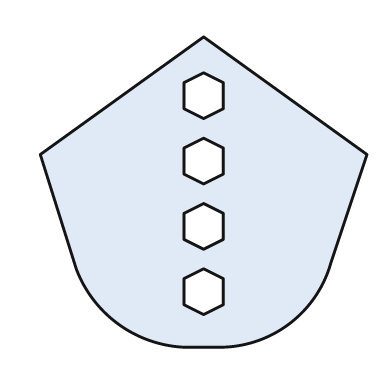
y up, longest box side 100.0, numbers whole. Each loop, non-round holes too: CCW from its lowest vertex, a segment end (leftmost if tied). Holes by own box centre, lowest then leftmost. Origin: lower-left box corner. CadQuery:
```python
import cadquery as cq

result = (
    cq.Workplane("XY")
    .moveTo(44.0, 0.0)
    .lineTo(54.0, 0.0)
    .threePointArc((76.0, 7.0), (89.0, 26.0))
    .lineTo(100.0, 59.0)
    .lineTo(50.0, 95.0)
    .lineTo(0.0, 59.0)
    .lineTo(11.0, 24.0)
    .threePointArc((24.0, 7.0), (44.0, 0.0))
    .close()
    .moveTo(50.0, 10.0)
    .lineTo(56.0, 13.0)
    .lineTo(56.0, 21.0)
    .lineTo(50.0, 24.0)
    .lineTo(44.0, 21.0)
    .lineTo(44.0, 13.0)
    .close()
    .moveTo(50.0, 30.0)
    .lineTo(56.0, 33.0)
    .lineTo(56.0, 41.0)
    .lineTo(50.0, 44.0)
    .lineTo(44.0, 41.0)
    .lineTo(44.0, 33.0)
    .close()
    .moveTo(50.0, 50.0)
    .lineTo(56.0, 53.0)
    .lineTo(56.0, 61.0)
    .lineTo(50.0, 64.0)
    .lineTo(44.0, 61.0)
    .lineTo(44.0, 53.0)
    .close()
    .moveTo(50.0, 70.0)
    .lineTo(56.0, 73.0)
    .lineTo(56.0, 81.0)
    .lineTo(50.0, 84.0)
    .lineTo(44.0, 81.0)
    .lineTo(44.0, 73.0)
    .close()
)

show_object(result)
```